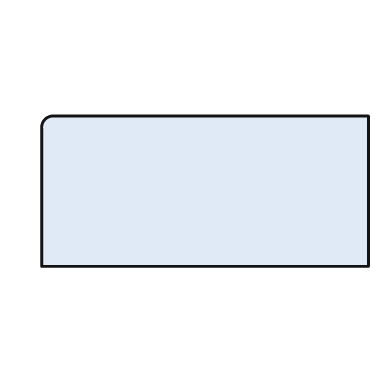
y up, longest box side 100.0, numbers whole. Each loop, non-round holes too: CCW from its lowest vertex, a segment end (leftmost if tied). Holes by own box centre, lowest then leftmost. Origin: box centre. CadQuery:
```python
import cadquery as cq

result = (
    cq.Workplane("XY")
    .moveTo(-50.0, -23.0)
    .lineTo(50.0, -23.0)
    .lineTo(50.0, 23.0)
    .lineTo(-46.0, 23.0)
    .threePointArc((-49.0, 22.0), (-50.0, 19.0))
    .close()
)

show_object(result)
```